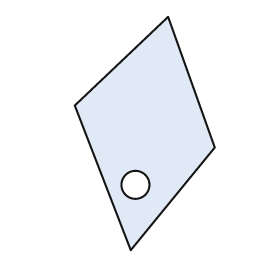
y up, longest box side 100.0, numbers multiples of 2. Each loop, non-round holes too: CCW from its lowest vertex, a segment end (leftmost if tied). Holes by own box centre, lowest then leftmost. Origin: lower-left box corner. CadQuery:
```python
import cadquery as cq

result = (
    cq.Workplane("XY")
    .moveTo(24.0, 0.0)
    .lineTo(60.0, 44.0)
    .lineTo(40.0, 100.0)
    .lineTo(0.0, 62.0)
    .close()
    .moveTo(26.0, 28.0)
    .circle(6.0)
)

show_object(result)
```